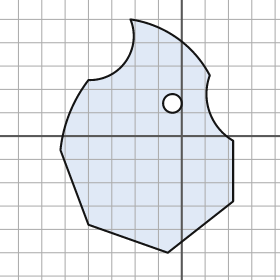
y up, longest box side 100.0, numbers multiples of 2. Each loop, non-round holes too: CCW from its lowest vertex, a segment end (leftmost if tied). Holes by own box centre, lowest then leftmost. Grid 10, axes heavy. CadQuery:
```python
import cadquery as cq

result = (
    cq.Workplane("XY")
    .moveTo(-6.0, -50.0)
    .lineTo(22.0, -28.0)
    .lineTo(22.0, -2.0)
    .threePointArc((12.0, 10.0), (12.0, 26.0))
    .threePointArc((-2.0, 42.0), (-22.0, 50.0))
    .threePointArc((-24.0, 32.0), (-40.0, 24.0))
    .threePointArc((-48.0, 10.0), (-52.0, -6.0))
    .lineTo(-40.0, -38.0)
    .close()
    .moveTo(-4.0, 14.0)
    .circle(4.0)
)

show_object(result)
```